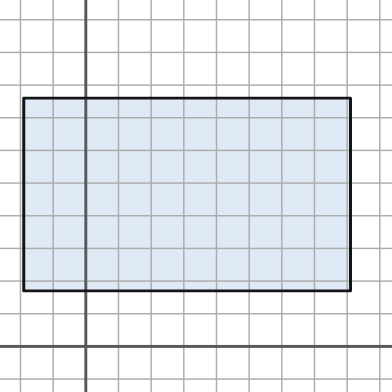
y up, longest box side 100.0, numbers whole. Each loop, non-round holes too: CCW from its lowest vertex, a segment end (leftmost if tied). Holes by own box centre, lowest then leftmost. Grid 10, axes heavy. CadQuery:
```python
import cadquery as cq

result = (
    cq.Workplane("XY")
    .moveTo(-19.0, 17.0)
    .lineTo(81.0, 17.0)
    .lineTo(81.0, 76.0)
    .lineTo(-19.0, 76.0)
    .close()
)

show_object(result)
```